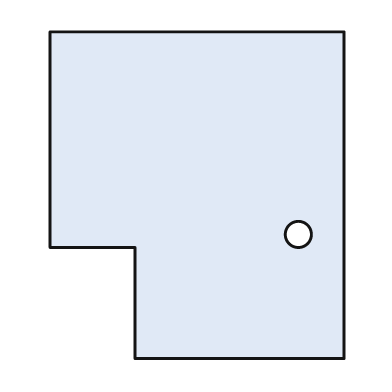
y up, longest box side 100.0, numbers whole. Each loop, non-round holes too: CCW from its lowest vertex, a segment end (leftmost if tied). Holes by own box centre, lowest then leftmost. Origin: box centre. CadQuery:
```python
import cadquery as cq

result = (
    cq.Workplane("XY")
    .moveTo(-19.0, -50.0)
    .lineTo(45.0, -50.0)
    .lineTo(45.0, 50.0)
    .lineTo(-45.0, 50.0)
    .lineTo(-45.0, -16.0)
    .lineTo(-19.0, -16.0)
    .close()
    .moveTo(31.0, -12.0)
    .circle(4.0)
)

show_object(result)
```